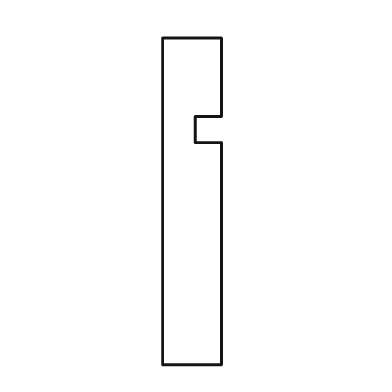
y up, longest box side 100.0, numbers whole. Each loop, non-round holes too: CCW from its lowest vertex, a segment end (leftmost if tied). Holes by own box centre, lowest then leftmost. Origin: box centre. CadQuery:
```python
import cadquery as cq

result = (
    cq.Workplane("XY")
    .moveTo(-9.0, -50.0)
    .lineTo(9.0, -50.0)
    .lineTo(9.0, 18.0)
    .lineTo(1.0, 18.0)
    .lineTo(1.0, 26.0)
    .lineTo(9.0, 26.0)
    .lineTo(9.0, 50.0)
    .lineTo(-9.0, 50.0)
    .close()
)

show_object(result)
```